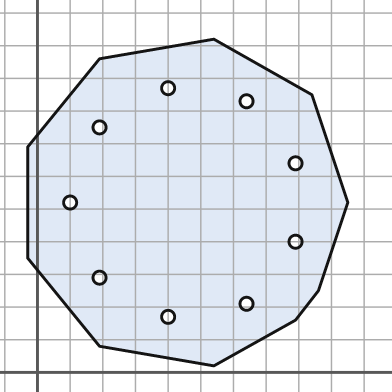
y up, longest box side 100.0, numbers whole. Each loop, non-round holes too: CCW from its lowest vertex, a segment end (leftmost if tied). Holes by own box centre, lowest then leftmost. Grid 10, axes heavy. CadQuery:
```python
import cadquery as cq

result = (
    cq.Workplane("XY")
    .moveTo(54.0, 2.0)
    .lineTo(79.0, 16.0)
    .lineTo(86.0, 25.0)
    .lineTo(95.0, 52.0)
    .lineTo(84.0, 85.0)
    .lineTo(54.0, 102.0)
    .lineTo(19.0, 96.0)
    .lineTo(-3.0, 69.0)
    .lineTo(-3.0, 35.0)
    .lineTo(19.0, 8.0)
    .close()
    .moveTo(40.0, 17.0)
    .circle(2.0)
    .moveTo(64.0, 21.0)
    .circle(2.0)
    .moveTo(19.0, 29.0)
    .circle(2.0)
    .moveTo(79.0, 40.0)
    .circle(2.0)
    .moveTo(10.0, 52.0)
    .circle(2.0)
    .moveTo(79.0, 64.0)
    .circle(2.0)
    .moveTo(19.0, 75.0)
    .circle(2.0)
    .moveTo(64.0, 83.0)
    .circle(2.0)
    .moveTo(40.0, 87.0)
    .circle(2.0)
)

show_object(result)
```